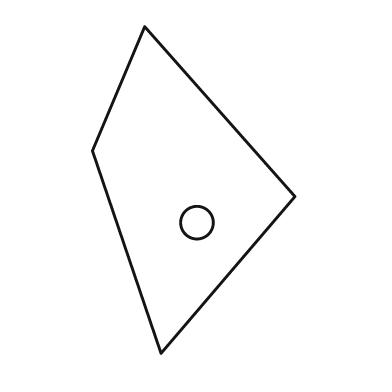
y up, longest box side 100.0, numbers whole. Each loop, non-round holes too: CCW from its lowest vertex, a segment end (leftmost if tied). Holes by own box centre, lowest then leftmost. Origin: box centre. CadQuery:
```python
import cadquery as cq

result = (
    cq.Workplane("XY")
    .moveTo(-10.0, -50.0)
    .lineTo(31.0, -2.0)
    .lineTo(-15.0, 50.0)
    .lineTo(-31.0, 12.0)
    .close()
    .moveTo(1.0, -10.0)
    .circle(5.0)
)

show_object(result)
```